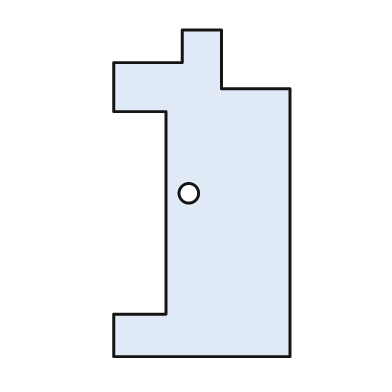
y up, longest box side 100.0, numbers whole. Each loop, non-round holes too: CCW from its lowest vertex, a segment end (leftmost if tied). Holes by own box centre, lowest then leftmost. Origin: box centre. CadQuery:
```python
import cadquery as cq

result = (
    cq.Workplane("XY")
    .moveTo(-27.0, -50.0)
    .lineTo(27.0, -50.0)
    .lineTo(27.0, 32.0)
    .lineTo(6.0, 32.0)
    .lineTo(6.0, 50.0)
    .lineTo(-6.0, 50.0)
    .lineTo(-6.0, 40.0)
    .lineTo(-27.0, 40.0)
    .lineTo(-27.0, 25.0)
    .lineTo(-11.0, 25.0)
    .lineTo(-11.0, -37.0)
    .lineTo(-27.0, -37.0)
    .close()
    .moveTo(-4.0, 0.0)
    .circle(3.0)
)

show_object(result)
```